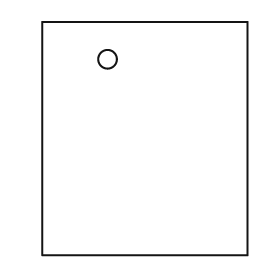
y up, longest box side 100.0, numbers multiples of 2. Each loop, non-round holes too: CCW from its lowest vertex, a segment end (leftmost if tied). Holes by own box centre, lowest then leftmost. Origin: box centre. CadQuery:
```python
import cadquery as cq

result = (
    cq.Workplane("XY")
    .moveTo(-44.0, -50.0)
    .lineTo(44.0, -50.0)
    .lineTo(44.0, 50.0)
    .lineTo(-44.0, 50.0)
    .close()
    .moveTo(-16.0, 34.0)
    .circle(4.0)
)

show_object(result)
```